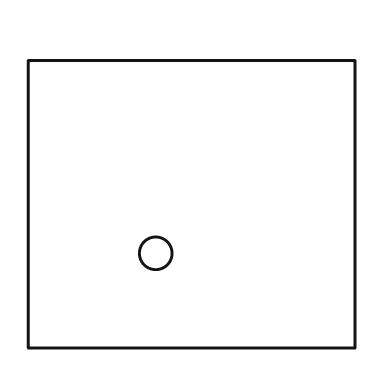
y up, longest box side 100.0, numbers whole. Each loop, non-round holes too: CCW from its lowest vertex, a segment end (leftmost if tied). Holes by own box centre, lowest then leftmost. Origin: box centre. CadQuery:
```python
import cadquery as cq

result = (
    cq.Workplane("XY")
    .moveTo(-50.0, -44.0)
    .lineTo(50.0, -44.0)
    .lineTo(50.0, 44.0)
    .lineTo(-50.0, 44.0)
    .close()
    .moveTo(-11.0, -15.0)
    .circle(5.0)
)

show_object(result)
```